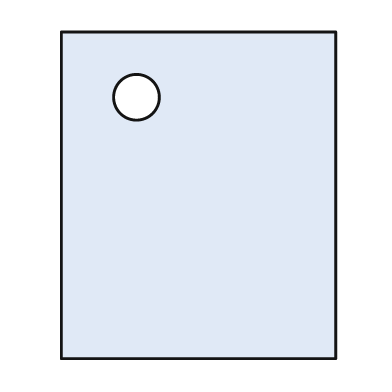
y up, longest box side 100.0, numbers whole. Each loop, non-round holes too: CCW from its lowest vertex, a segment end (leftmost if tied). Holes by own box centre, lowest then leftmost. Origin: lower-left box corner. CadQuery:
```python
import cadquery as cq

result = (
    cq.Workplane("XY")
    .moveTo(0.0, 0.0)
    .lineTo(84.0, 0.0)
    .lineTo(84.0, 100.0)
    .lineTo(0.0, 100.0)
    .close()
    .moveTo(23.0, 80.0)
    .circle(7.0)
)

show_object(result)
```